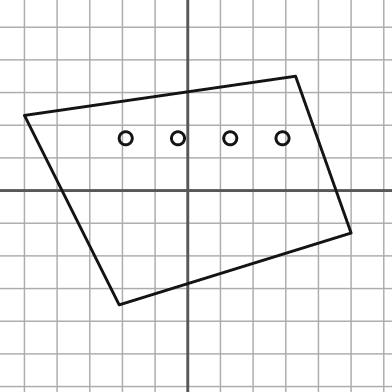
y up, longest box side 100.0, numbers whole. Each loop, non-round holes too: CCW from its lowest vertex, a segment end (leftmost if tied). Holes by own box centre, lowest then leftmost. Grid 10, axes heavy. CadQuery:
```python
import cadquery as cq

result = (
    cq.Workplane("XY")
    .moveTo(-21.0, -35.0)
    .lineTo(50.0, -13.0)
    .lineTo(33.0, 35.0)
    .lineTo(-50.0, 23.0)
    .close()
    .moveTo(-19.0, 16.0)
    .circle(2.0)
    .moveTo(-3.0, 16.0)
    .circle(2.0)
    .moveTo(13.0, 16.0)
    .circle(2.0)
    .moveTo(29.0, 16.0)
    .circle(2.0)
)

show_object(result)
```